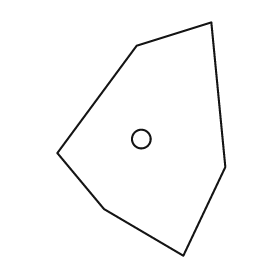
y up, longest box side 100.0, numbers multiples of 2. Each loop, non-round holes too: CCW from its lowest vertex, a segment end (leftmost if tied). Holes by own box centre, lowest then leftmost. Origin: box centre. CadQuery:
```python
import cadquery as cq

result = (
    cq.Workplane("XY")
    .moveTo(18.0, -50.0)
    .lineTo(36.0, -12.0)
    .lineTo(30.0, 50.0)
    .lineTo(-2.0, 40.0)
    .lineTo(-36.0, -6.0)
    .lineTo(-16.0, -30.0)
    .close()
    .moveTo(0.0, 0.0)
    .circle(4.0)
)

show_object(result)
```